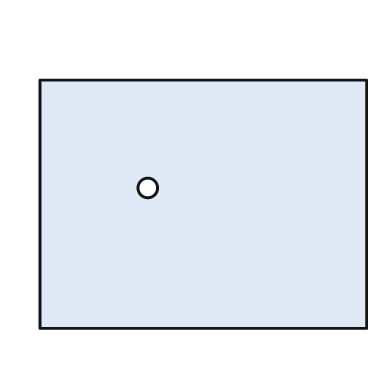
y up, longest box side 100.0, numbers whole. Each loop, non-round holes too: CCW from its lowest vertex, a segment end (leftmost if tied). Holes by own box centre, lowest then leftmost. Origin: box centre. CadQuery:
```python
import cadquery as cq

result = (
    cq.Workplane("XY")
    .moveTo(-50.0, -38.0)
    .lineTo(50.0, -38.0)
    .lineTo(50.0, 38.0)
    .lineTo(-50.0, 38.0)
    .close()
    .moveTo(-17.0, 5.0)
    .circle(3.0)
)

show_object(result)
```